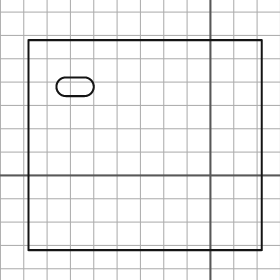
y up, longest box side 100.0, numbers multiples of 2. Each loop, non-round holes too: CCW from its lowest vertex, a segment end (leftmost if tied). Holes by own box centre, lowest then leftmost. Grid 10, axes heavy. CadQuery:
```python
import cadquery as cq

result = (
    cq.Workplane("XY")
    .moveTo(-78.0, -32.0)
    .lineTo(22.0, -32.0)
    .lineTo(22.0, 58.0)
    .lineTo(-78.0, 58.0)
    .close()
    .moveTo(-62.0, 34.0)
    .lineTo(-54.0, 34.0)
    .threePointArc((-50.0, 38.0), (-54.0, 42.0))
    .lineTo(-62.0, 42.0)
    .threePointArc((-66.0, 38.0), (-62.0, 34.0))
    .close()
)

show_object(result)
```